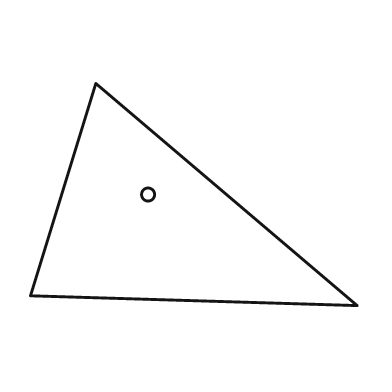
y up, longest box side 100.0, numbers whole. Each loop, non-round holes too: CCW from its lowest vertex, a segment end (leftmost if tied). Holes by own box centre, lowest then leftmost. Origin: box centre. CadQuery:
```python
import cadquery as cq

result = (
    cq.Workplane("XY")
    .moveTo(50.0, -34.0)
    .lineTo(-30.0, 34.0)
    .lineTo(-50.0, -31.0)
    .close()
    .moveTo(-14.0, 0.0)
    .circle(2.0)
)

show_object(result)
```